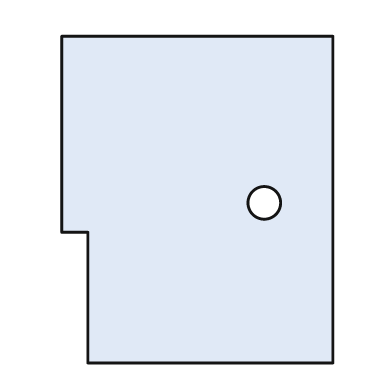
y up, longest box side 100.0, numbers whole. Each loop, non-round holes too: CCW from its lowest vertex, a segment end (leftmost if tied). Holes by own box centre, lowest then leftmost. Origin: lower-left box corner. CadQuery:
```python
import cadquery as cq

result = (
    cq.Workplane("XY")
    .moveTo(8.0, 0.0)
    .lineTo(83.0, 0.0)
    .lineTo(83.0, 100.0)
    .lineTo(0.0, 100.0)
    .lineTo(0.0, 40.0)
    .lineTo(8.0, 40.0)
    .close()
    .moveTo(62.0, 49.0)
    .circle(5.0)
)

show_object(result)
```